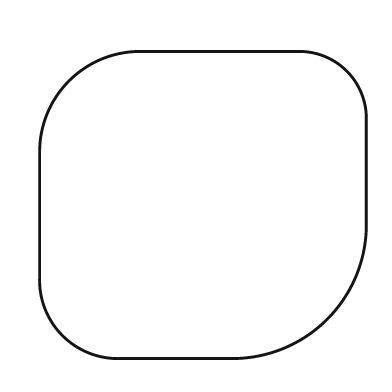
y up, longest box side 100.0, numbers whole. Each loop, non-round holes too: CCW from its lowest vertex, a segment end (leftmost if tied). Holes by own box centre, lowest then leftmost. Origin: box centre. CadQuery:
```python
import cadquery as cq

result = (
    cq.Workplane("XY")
    .moveTo(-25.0, -47.0)
    .lineTo(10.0, -47.0)
    .threePointArc((38.0, -35.0), (50.0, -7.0))
    .lineTo(50.0, 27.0)
    .threePointArc((44.0, 41.0), (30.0, 47.0))
    .lineTo(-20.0, 47.0)
    .threePointArc((-41.0, 38.0), (-50.0, 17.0))
    .lineTo(-50.0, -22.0)
    .threePointArc((-43.0, -40.0), (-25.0, -47.0))
    .close()
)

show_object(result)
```